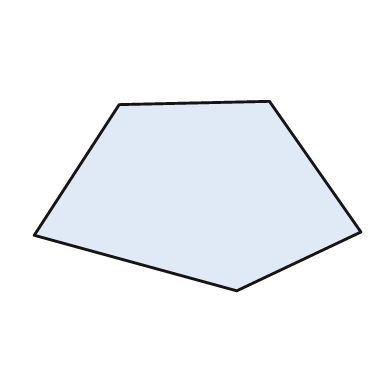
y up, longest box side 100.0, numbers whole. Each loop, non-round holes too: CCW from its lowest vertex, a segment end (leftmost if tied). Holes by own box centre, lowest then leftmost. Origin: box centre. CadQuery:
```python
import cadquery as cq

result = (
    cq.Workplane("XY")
    .moveTo(12.0, -29.0)
    .lineTo(50.0, -11.0)
    .lineTo(22.0, 29.0)
    .lineTo(-24.0, 28.0)
    .lineTo(-50.0, -12.0)
    .close()
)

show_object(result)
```